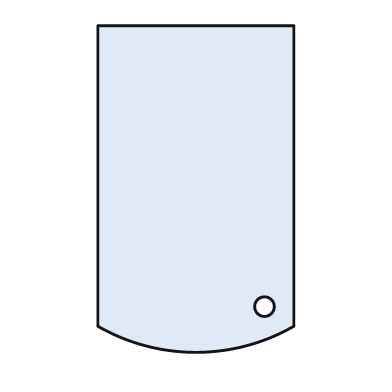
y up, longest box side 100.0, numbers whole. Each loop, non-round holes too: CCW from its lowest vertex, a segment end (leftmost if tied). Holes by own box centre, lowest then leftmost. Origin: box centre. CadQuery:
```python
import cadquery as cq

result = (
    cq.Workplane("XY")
    .moveTo(-30.0, -42.0)
    .threePointArc((0.0, -50.0), (30.0, -42.0))
    .lineTo(30.0, 50.0)
    .lineTo(-30.0, 50.0)
    .close()
    .moveTo(21.0, -36.0)
    .circle(3.0)
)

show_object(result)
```